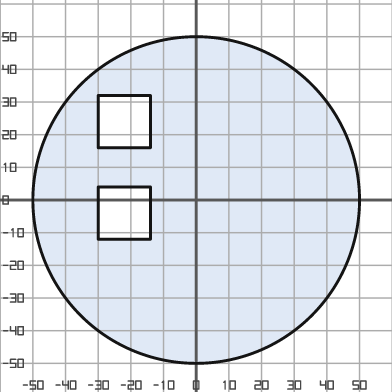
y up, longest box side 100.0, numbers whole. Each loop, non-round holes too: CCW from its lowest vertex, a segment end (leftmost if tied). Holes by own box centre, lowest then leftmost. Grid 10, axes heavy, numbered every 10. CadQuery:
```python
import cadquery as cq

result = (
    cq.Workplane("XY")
    .moveTo(0.0, 0.0)
    .circle(50.0)
    .moveTo(-30.0, -12.0)
    .lineTo(-14.0, -12.0)
    .lineTo(-14.0, 4.0)
    .lineTo(-30.0, 4.0)
    .close()
    .moveTo(-30.0, 16.0)
    .lineTo(-14.0, 16.0)
    .lineTo(-14.0, 32.0)
    .lineTo(-30.0, 32.0)
    .close()
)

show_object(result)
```